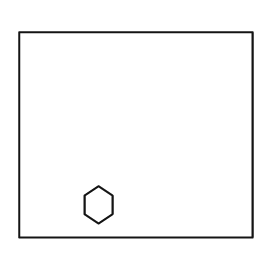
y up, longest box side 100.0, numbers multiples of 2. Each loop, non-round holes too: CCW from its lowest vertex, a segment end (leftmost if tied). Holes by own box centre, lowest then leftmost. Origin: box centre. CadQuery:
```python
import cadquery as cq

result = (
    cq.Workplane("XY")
    .moveTo(-50.0, -44.0)
    .lineTo(50.0, -44.0)
    .lineTo(50.0, 44.0)
    .lineTo(-50.0, 44.0)
    .close()
    .moveTo(-16.0, -38.0)
    .lineTo(-10.0, -34.0)
    .lineTo(-10.0, -26.0)
    .lineTo(-16.0, -22.0)
    .lineTo(-22.0, -26.0)
    .lineTo(-22.0, -34.0)
    .close()
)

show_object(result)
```